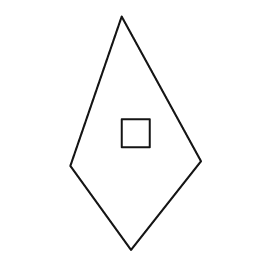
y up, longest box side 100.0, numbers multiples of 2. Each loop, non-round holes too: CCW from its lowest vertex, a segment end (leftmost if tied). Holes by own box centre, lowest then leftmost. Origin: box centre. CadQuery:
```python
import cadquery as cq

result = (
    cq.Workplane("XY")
    .moveTo(-2.0, -50.0)
    .lineTo(28.0, -12.0)
    .lineTo(-6.0, 50.0)
    .lineTo(-28.0, -14.0)
    .close()
    .moveTo(-6.0, -6.0)
    .lineTo(6.0, -6.0)
    .lineTo(6.0, 6.0)
    .lineTo(-6.0, 6.0)
    .close()
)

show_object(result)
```